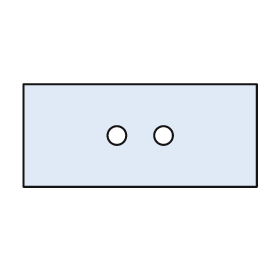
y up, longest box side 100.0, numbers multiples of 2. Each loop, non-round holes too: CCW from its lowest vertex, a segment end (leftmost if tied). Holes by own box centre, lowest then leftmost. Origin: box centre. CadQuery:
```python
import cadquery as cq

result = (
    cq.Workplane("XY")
    .moveTo(-50.0, -22.0)
    .lineTo(50.0, -22.0)
    .lineTo(50.0, 22.0)
    .lineTo(-50.0, 22.0)
    .close()
    .moveTo(-10.0, 0.0)
    .circle(4.0)
    .moveTo(10.0, 0.0)
    .circle(4.0)
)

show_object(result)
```